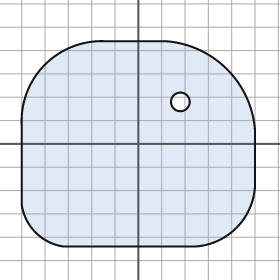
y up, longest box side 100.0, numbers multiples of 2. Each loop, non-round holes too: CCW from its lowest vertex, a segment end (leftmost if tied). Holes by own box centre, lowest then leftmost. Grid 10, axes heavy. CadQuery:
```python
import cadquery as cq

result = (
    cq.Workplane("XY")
    .moveTo(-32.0, -44.0)
    .lineTo(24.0, -44.0)
    .threePointArc((42.0, -36.0), (50.0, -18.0))
    .lineTo(50.0, 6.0)
    .threePointArc((38.0, 32.0), (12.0, 44.0))
    .lineTo(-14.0, 44.0)
    .threePointArc((-40.0, 34.0), (-50.0, 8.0))
    .lineTo(-50.0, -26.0)
    .threePointArc((-44.0, -38.0), (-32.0, -44.0))
    .close()
    .moveTo(18.0, 18.0)
    .circle(4.0)
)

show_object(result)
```